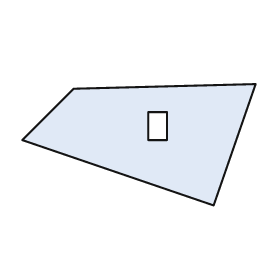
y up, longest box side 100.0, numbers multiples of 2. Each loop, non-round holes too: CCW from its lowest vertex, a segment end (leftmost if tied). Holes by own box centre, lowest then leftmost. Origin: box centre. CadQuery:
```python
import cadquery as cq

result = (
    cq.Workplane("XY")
    .moveTo(32.0, -26.0)
    .lineTo(50.0, 26.0)
    .lineTo(-28.0, 24.0)
    .lineTo(-50.0, 2.0)
    .close()
    .moveTo(4.0, 2.0)
    .lineTo(12.0, 2.0)
    .lineTo(12.0, 14.0)
    .lineTo(4.0, 14.0)
    .close()
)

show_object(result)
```